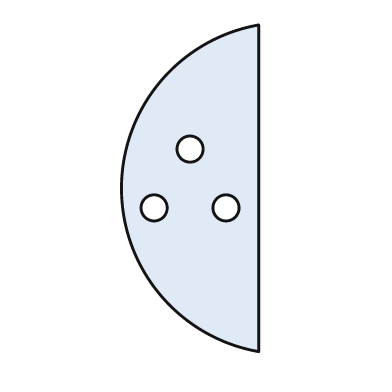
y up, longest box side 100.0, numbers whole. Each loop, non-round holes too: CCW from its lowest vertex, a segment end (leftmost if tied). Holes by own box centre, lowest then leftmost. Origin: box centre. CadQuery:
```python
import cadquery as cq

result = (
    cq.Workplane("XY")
    .moveTo(21.0, -50.0)
    .lineTo(21.0, 50.0)
    .threePointArc((-21.0, 0.0), (21.0, -50.0))
    .close()
    .moveTo(-11.0, -6.0)
    .circle(4.0)
    .moveTo(11.0, -6.0)
    .circle(4.0)
    .moveTo(0.0, 12.0)
    .circle(4.0)
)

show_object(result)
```